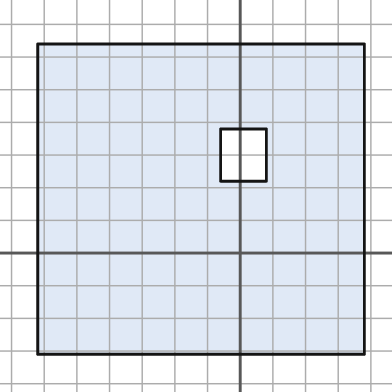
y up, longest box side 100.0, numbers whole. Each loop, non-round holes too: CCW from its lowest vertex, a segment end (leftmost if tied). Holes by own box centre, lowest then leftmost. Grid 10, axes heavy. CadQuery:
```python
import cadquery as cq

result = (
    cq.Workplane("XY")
    .moveTo(-62.0, -31.0)
    .lineTo(38.0, -31.0)
    .lineTo(38.0, 64.0)
    .lineTo(-62.0, 64.0)
    .close()
    .moveTo(-6.0, 22.0)
    .lineTo(8.0, 22.0)
    .lineTo(8.0, 38.0)
    .lineTo(-6.0, 38.0)
    .close()
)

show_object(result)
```